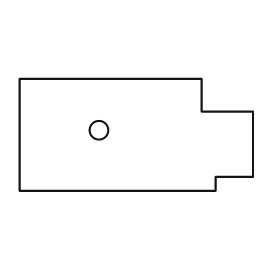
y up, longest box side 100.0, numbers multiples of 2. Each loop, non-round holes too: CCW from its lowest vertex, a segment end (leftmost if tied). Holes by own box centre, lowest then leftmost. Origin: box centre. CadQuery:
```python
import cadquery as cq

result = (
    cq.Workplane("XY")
    .moveTo(-50.0, -24.0)
    .lineTo(34.0, -24.0)
    .lineTo(34.0, -18.0)
    .lineTo(50.0, -18.0)
    .lineTo(50.0, 10.0)
    .lineTo(28.0, 10.0)
    .lineTo(28.0, 24.0)
    .lineTo(-50.0, 24.0)
    .close()
    .moveTo(-16.0, 2.0)
    .circle(4.0)
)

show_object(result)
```